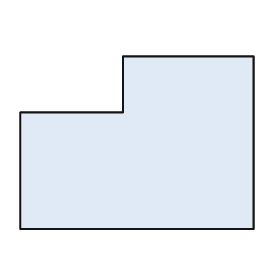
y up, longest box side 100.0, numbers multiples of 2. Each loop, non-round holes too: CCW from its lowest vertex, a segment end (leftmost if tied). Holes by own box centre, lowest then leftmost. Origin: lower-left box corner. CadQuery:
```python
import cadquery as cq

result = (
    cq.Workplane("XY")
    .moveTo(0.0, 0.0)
    .lineTo(100.0, 0.0)
    .lineTo(100.0, 74.0)
    .lineTo(44.0, 74.0)
    .lineTo(44.0, 50.0)
    .lineTo(0.0, 50.0)
    .close()
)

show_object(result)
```